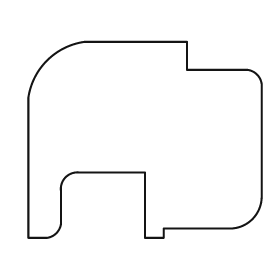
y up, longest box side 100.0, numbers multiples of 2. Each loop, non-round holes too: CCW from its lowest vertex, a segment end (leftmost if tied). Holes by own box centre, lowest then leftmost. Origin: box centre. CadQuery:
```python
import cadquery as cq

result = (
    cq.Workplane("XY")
    .moveTo(-50.0, -42.0)
    .lineTo(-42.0, -42.0)
    .threePointArc((-38.0, -40.0), (-36.0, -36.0))
    .lineTo(-36.0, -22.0)
    .threePointArc((-34.0, -16.0), (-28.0, -14.0))
    .lineTo(0.0, -14.0)
    .lineTo(0.0, -42.0)
    .lineTo(8.0, -42.0)
    .lineTo(8.0, -38.0)
    .lineTo(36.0, -38.0)
    .threePointArc((46.0, -34.0), (50.0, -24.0))
    .lineTo(50.0, 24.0)
    .threePointArc((48.0, 28.0), (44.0, 30.0))
    .lineTo(18.0, 30.0)
    .lineTo(18.0, 42.0)
    .lineTo(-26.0, 42.0)
    .threePointArc((-42.0, 34.0), (-50.0, 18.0))
    .close()
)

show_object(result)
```